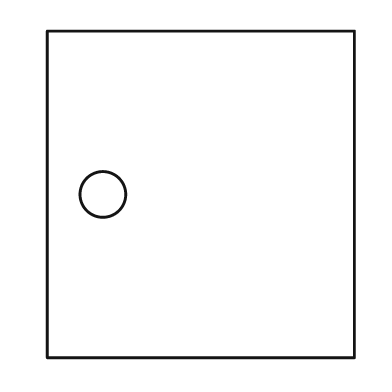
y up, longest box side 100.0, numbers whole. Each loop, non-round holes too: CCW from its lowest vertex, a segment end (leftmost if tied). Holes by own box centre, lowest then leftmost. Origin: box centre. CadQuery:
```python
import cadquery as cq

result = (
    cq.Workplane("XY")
    .moveTo(-47.0, -50.0)
    .lineTo(47.0, -50.0)
    .lineTo(47.0, 50.0)
    .lineTo(-47.0, 50.0)
    .close()
    .moveTo(-30.0, 0.0)
    .circle(7.0)
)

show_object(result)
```